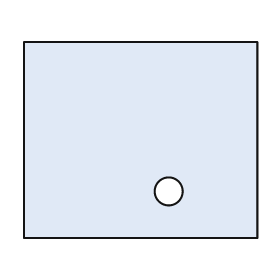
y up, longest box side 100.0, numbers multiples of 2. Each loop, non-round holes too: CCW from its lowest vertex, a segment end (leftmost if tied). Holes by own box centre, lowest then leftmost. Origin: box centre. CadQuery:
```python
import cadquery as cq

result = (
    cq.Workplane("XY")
    .moveTo(-50.0, -42.0)
    .lineTo(50.0, -42.0)
    .lineTo(50.0, 42.0)
    .lineTo(-50.0, 42.0)
    .close()
    .moveTo(12.0, -22.0)
    .circle(6.0)
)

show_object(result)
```